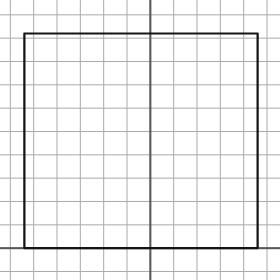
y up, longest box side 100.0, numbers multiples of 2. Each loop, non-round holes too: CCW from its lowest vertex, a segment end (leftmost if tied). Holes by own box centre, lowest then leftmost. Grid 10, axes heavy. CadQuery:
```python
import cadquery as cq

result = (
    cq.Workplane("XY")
    .moveTo(-54.0, 0.0)
    .lineTo(46.0, 0.0)
    .lineTo(46.0, 92.0)
    .lineTo(-54.0, 92.0)
    .close()
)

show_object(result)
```